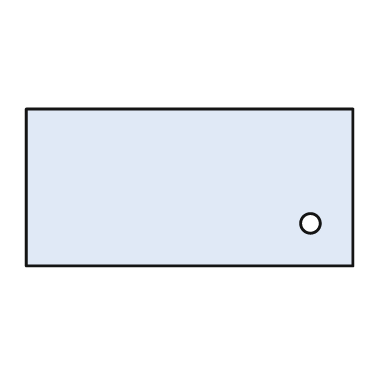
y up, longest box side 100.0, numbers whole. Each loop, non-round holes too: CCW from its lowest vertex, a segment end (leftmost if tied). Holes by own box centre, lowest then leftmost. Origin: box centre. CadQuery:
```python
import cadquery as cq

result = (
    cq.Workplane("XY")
    .moveTo(-50.0, -24.0)
    .lineTo(50.0, -24.0)
    .lineTo(50.0, 24.0)
    .lineTo(-50.0, 24.0)
    .close()
    .moveTo(37.0, -11.0)
    .circle(3.0)
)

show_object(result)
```